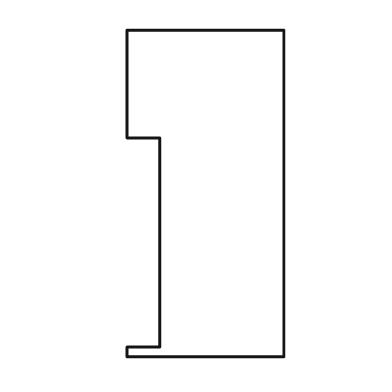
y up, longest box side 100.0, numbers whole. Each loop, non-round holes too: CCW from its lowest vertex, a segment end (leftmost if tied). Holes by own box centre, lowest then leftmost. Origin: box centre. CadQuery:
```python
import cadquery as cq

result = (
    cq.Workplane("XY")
    .moveTo(-24.0, -50.0)
    .lineTo(24.0, -50.0)
    .lineTo(24.0, 50.0)
    .lineTo(-24.0, 50.0)
    .lineTo(-24.0, 17.0)
    .lineTo(-14.0, 17.0)
    .lineTo(-14.0, -47.0)
    .lineTo(-24.0, -47.0)
    .close()
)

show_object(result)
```